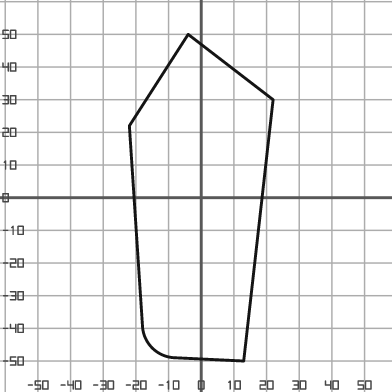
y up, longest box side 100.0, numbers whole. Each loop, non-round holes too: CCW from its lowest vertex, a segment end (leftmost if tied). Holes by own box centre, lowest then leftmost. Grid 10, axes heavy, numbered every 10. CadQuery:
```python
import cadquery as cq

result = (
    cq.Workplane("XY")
    .moveTo(13.0, -50.0)
    .lineTo(22.0, 30.0)
    .lineTo(-4.0, 50.0)
    .lineTo(-22.0, 22.0)
    .lineTo(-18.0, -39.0)
    .threePointArc((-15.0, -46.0), (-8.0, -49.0))
    .close()
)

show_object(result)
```